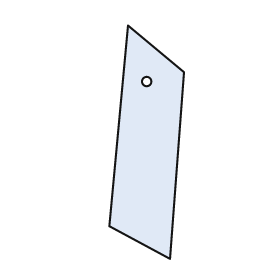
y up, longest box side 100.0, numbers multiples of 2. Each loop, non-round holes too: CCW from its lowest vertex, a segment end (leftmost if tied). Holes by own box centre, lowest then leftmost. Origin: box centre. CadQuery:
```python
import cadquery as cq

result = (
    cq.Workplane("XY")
    .moveTo(10.0, -50.0)
    .lineTo(16.0, 30.0)
    .lineTo(-8.0, 50.0)
    .lineTo(-16.0, -36.0)
    .close()
    .moveTo(0.0, 26.0)
    .circle(2.0)
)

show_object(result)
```